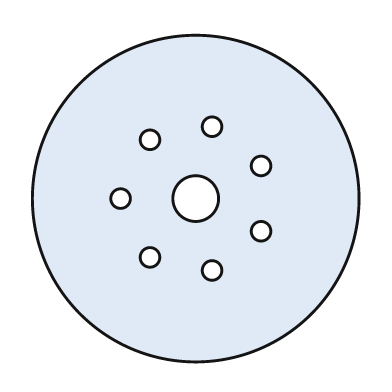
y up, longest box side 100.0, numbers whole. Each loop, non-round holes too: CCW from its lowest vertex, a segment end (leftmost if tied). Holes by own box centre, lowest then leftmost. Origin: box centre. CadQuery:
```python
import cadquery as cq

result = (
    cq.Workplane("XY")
    .moveTo(0.0, 0.0)
    .circle(50.0)
    .moveTo(5.0, -22.0)
    .circle(3.0)
    .moveTo(-14.0, -18.0)
    .circle(3.0)
    .moveTo(20.0, -10.0)
    .circle(3.0)
    .moveTo(-23.0, 0.0)
    .circle(3.0)
    .moveTo(0.0, 0.0)
    .circle(7.0)
    .moveTo(20.0, 10.0)
    .circle(3.0)
    .moveTo(-14.0, 18.0)
    .circle(3.0)
    .moveTo(5.0, 22.0)
    .circle(3.0)
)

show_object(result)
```